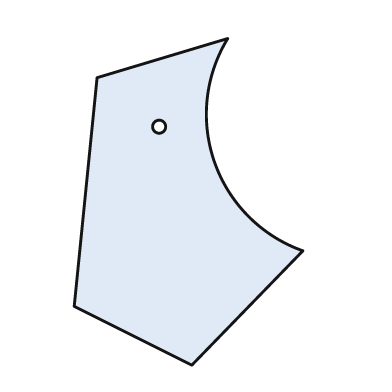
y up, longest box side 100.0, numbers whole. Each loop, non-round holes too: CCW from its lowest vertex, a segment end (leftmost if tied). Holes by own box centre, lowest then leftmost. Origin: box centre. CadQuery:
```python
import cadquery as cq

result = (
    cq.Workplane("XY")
    .moveTo(1.0, -50.0)
    .lineTo(35.0, -15.0)
    .threePointArc((8.0, 12.0), (12.0, 50.0))
    .lineTo(-28.0, 38.0)
    .lineTo(-35.0, -32.0)
    .close()
    .moveTo(-9.0, 23.0)
    .circle(2.0)
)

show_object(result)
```